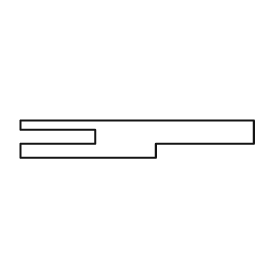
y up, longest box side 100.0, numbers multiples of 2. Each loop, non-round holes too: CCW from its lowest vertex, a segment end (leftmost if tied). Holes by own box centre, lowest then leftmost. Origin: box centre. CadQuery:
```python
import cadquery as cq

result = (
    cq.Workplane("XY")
    .moveTo(-50.0, -8.0)
    .lineTo(8.0, -8.0)
    .lineTo(8.0, -2.0)
    .lineTo(50.0, -2.0)
    .lineTo(50.0, 8.0)
    .lineTo(-50.0, 8.0)
    .lineTo(-50.0, 4.0)
    .lineTo(-18.0, 4.0)
    .lineTo(-18.0, -2.0)
    .lineTo(-50.0, -2.0)
    .close()
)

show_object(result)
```